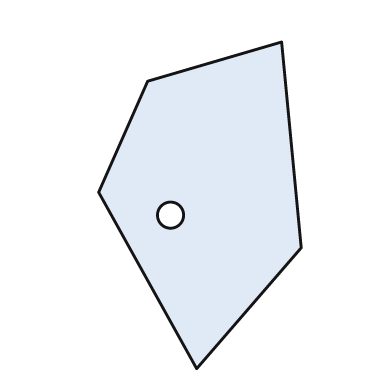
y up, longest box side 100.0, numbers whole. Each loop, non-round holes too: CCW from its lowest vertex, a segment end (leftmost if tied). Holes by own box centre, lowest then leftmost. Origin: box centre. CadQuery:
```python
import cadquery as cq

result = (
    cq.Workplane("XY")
    .moveTo(-1.0, -50.0)
    .lineTo(31.0, -13.0)
    .lineTo(25.0, 50.0)
    .lineTo(-16.0, 38.0)
    .lineTo(-31.0, 4.0)
    .close()
    .moveTo(-9.0, -3.0)
    .circle(4.0)
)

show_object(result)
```